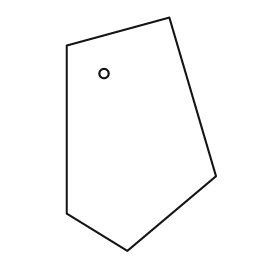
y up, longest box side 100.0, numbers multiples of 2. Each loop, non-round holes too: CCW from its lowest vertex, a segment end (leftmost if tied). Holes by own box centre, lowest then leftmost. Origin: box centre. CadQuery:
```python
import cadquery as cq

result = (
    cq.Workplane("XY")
    .moveTo(-6.0, -50.0)
    .lineTo(32.0, -18.0)
    .lineTo(12.0, 50.0)
    .lineTo(-32.0, 38.0)
    .lineTo(-32.0, -34.0)
    .close()
    .moveTo(-16.0, 26.0)
    .circle(2.0)
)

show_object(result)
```